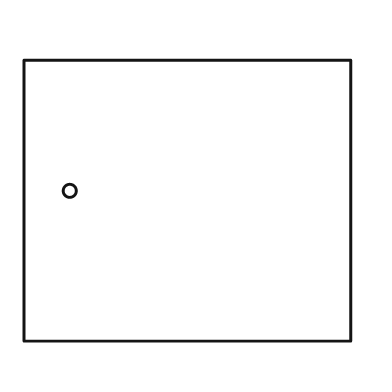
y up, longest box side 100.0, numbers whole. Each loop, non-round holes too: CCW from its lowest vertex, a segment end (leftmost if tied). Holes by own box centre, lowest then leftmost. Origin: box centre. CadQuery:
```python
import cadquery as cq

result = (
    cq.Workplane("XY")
    .moveTo(-50.0, -43.0)
    .lineTo(50.0, -43.0)
    .lineTo(50.0, 43.0)
    .lineTo(-50.0, 43.0)
    .close()
    .moveTo(-36.0, 3.0)
    .circle(2.0)
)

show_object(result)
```